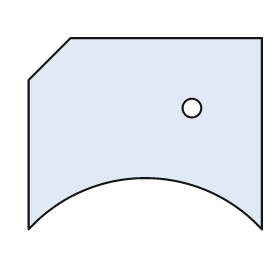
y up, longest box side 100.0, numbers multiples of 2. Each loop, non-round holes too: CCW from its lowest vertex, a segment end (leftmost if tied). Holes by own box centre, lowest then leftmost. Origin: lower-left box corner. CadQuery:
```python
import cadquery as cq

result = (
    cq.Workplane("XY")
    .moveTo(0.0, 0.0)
    .threePointArc((50.0, 22.0), (100.0, 0.0))
    .lineTo(100.0, 82.0)
    .lineTo(18.0, 82.0)
    .lineTo(0.0, 64.0)
    .close()
    .moveTo(70.0, 52.0)
    .circle(4.0)
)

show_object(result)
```